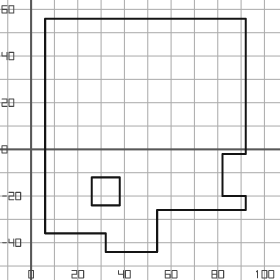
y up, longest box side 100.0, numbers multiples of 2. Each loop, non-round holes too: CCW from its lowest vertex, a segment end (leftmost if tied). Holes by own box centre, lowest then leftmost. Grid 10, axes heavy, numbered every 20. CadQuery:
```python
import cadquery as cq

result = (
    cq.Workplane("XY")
    .moveTo(32.0, -44.0)
    .lineTo(54.0, -44.0)
    .lineTo(54.0, -26.0)
    .lineTo(92.0, -26.0)
    .lineTo(92.0, -20.0)
    .lineTo(82.0, -20.0)
    .lineTo(82.0, -2.0)
    .lineTo(92.0, -2.0)
    .lineTo(92.0, 56.0)
    .lineTo(6.0, 56.0)
    .lineTo(6.0, -36.0)
    .lineTo(32.0, -36.0)
    .close()
    .moveTo(26.0, -24.0)
    .lineTo(38.0, -24.0)
    .lineTo(38.0, -12.0)
    .lineTo(26.0, -12.0)
    .close()
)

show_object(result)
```